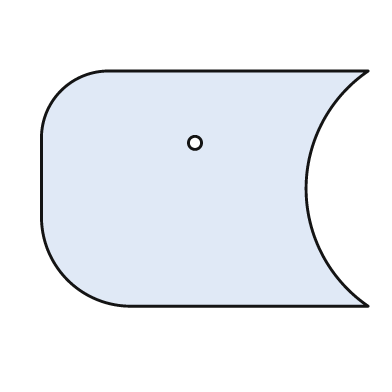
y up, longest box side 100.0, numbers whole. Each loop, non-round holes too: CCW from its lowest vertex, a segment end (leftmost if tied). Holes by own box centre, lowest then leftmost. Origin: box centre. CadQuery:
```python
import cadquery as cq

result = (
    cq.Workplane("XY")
    .moveTo(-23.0, -36.0)
    .lineTo(50.0, -36.0)
    .threePointArc((31.0, 0.0), (50.0, 36.0))
    .lineTo(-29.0, 36.0)
    .threePointArc((-44.0, 30.0), (-50.0, 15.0))
    .lineTo(-50.0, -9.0)
    .threePointArc((-42.0, -28.0), (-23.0, -36.0))
    .close()
    .moveTo(-3.0, 14.0)
    .circle(2.0)
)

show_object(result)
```